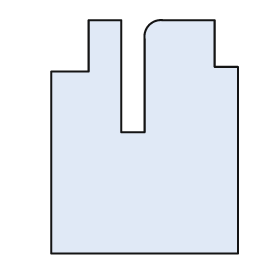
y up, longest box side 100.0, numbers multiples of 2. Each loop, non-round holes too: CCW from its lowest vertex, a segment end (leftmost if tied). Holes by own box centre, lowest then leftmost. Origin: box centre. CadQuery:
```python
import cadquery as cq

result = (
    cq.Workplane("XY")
    .moveTo(-40.0, -50.0)
    .lineTo(40.0, -50.0)
    .lineTo(40.0, 30.0)
    .lineTo(30.0, 30.0)
    .lineTo(30.0, 50.0)
    .lineTo(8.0, 50.0)
    .threePointArc((2.0, 48.0), (0.0, 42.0))
    .lineTo(0.0, 2.0)
    .lineTo(-10.0, 2.0)
    .lineTo(-10.0, 50.0)
    .lineTo(-24.0, 50.0)
    .lineTo(-24.0, 28.0)
    .lineTo(-40.0, 28.0)
    .close()
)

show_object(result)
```